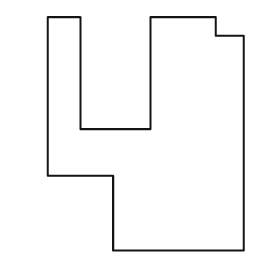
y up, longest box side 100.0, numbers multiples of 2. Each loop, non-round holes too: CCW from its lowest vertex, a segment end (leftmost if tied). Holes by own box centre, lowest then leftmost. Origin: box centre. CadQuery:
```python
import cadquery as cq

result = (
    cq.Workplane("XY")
    .moveTo(-14.0, -50.0)
    .lineTo(42.0, -50.0)
    .lineTo(42.0, 42.0)
    .lineTo(30.0, 42.0)
    .lineTo(30.0, 50.0)
    .lineTo(2.0, 50.0)
    .lineTo(2.0, 2.0)
    .lineTo(-28.0, 2.0)
    .lineTo(-28.0, 50.0)
    .lineTo(-42.0, 50.0)
    .lineTo(-42.0, -18.0)
    .lineTo(-14.0, -18.0)
    .close()
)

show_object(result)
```